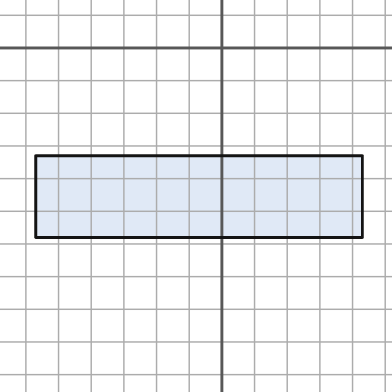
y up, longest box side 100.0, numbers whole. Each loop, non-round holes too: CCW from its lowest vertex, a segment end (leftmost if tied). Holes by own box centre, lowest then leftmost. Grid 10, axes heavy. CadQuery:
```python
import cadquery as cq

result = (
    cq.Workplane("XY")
    .moveTo(-57.0, -58.0)
    .lineTo(43.0, -58.0)
    .lineTo(43.0, -33.0)
    .lineTo(-57.0, -33.0)
    .close()
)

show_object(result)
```